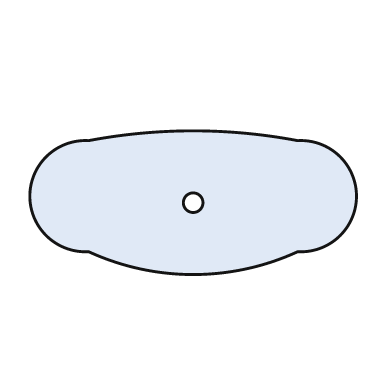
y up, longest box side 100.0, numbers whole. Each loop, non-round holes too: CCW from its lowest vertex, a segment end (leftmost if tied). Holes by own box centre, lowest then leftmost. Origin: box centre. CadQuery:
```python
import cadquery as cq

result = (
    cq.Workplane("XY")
    .moveTo(-32.0, -15.0)
    .threePointArc((0.0, -22.0), (32.0, -15.0))
    .threePointArc((50.0, 2.0), (32.0, 19.0))
    .threePointArc((0.0, 22.0), (-32.0, 19.0))
    .threePointArc((-50.0, 2.0), (-32.0, -15.0))
    .close()
    .moveTo(0.0, 0.0)
    .circle(3.0)
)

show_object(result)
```